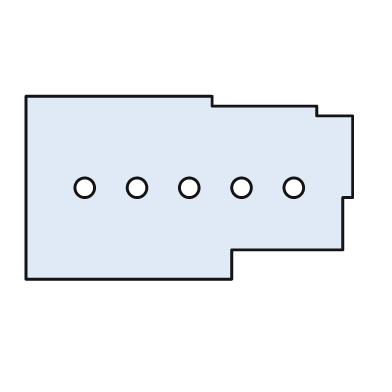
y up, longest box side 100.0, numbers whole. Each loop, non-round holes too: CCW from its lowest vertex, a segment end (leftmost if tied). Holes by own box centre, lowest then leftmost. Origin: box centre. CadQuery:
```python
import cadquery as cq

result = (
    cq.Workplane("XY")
    .moveTo(-50.0, -28.0)
    .lineTo(13.0, -28.0)
    .lineTo(13.0, -19.0)
    .lineTo(47.0, -19.0)
    .lineTo(47.0, -3.0)
    .lineTo(50.0, -3.0)
    .lineTo(50.0, 22.0)
    .lineTo(39.0, 22.0)
    .lineTo(39.0, 25.0)
    .lineTo(7.0, 25.0)
    .lineTo(7.0, 28.0)
    .lineTo(-50.0, 28.0)
    .close()
    .moveTo(-32.0, 0.0)
    .circle(3.0)
    .moveTo(-16.0, 0.0)
    .circle(3.0)
    .moveTo(0.0, 0.0)
    .circle(3.0)
    .moveTo(16.0, 0.0)
    .circle(3.0)
    .moveTo(32.0, 0.0)
    .circle(3.0)
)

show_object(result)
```